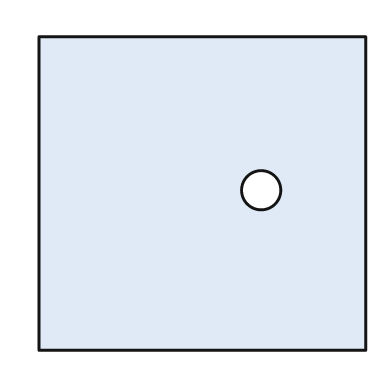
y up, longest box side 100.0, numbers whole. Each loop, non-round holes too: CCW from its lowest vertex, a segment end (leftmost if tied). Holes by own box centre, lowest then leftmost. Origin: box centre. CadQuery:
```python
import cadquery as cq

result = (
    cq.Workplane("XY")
    .moveTo(-50.0, -48.0)
    .lineTo(50.0, -48.0)
    .lineTo(50.0, 48.0)
    .lineTo(-50.0, 48.0)
    .close()
    .moveTo(18.0, 1.0)
    .circle(6.0)
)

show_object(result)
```